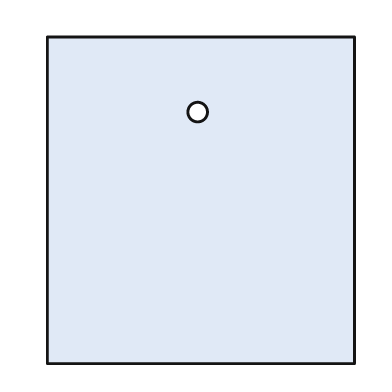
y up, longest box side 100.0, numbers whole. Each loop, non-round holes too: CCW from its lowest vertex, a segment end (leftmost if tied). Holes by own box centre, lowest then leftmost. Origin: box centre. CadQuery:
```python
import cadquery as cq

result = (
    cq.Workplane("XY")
    .moveTo(-47.0, -50.0)
    .lineTo(47.0, -50.0)
    .lineTo(47.0, 50.0)
    .lineTo(-47.0, 50.0)
    .close()
    .moveTo(-1.0, 27.0)
    .circle(3.0)
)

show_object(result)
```